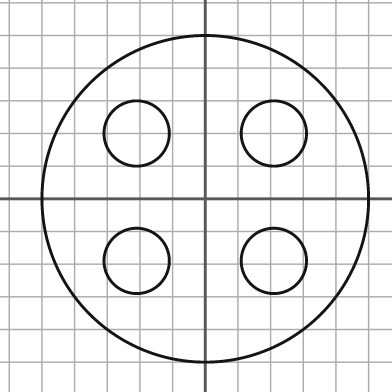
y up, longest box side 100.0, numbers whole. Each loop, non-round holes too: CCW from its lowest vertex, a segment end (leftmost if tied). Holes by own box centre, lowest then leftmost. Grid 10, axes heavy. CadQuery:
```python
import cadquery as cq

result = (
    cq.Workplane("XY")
    .moveTo(0.0, 0.0)
    .circle(50.0)
    .moveTo(-21.0, -19.0)
    .circle(10.0)
    .moveTo(21.0, -19.0)
    .circle(10.0)
    .moveTo(-21.0, 20.0)
    .circle(10.0)
    .moveTo(21.0, 20.0)
    .circle(10.0)
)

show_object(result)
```